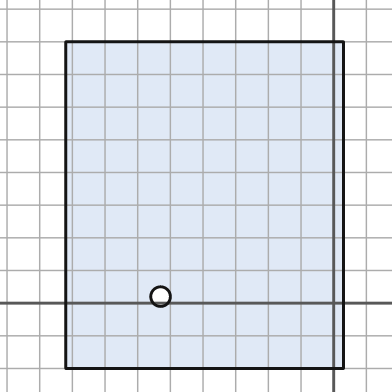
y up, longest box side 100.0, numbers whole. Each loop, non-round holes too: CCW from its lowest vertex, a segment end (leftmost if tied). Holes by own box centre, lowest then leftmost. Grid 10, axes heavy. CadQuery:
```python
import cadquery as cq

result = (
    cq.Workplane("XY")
    .moveTo(-82.0, -20.0)
    .lineTo(3.0, -20.0)
    .lineTo(3.0, 80.0)
    .lineTo(-82.0, 80.0)
    .close()
    .moveTo(-53.0, 2.0)
    .circle(3.0)
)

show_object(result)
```